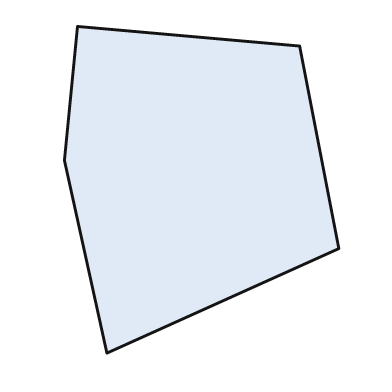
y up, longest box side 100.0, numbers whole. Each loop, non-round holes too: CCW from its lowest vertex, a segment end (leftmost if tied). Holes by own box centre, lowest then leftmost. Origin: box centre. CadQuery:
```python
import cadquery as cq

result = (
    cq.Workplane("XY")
    .moveTo(-29.0, -50.0)
    .lineTo(42.0, -18.0)
    .lineTo(30.0, 44.0)
    .lineTo(-38.0, 50.0)
    .lineTo(-42.0, 9.0)
    .close()
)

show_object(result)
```